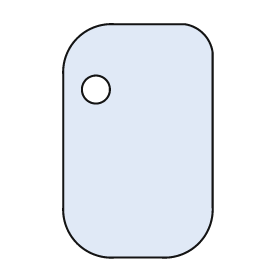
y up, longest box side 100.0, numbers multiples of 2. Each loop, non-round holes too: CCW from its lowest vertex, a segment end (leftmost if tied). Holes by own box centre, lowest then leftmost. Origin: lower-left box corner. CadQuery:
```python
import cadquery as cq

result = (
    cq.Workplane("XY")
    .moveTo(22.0, 0.0)
    .lineTo(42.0, 0.0)
    .threePointArc((58.0, 6.0), (64.0, 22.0))
    .lineTo(64.0, 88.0)
    .threePointArc((60.0, 96.0), (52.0, 100.0))
    .lineTo(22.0, 100.0)
    .threePointArc((6.0, 94.0), (0.0, 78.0))
    .lineTo(0.0, 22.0)
    .threePointArc((6.0, 6.0), (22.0, 0.0))
    .close()
    .moveTo(14.0, 72.0)
    .circle(6.0)
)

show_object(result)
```